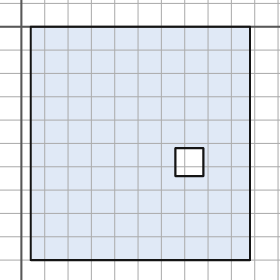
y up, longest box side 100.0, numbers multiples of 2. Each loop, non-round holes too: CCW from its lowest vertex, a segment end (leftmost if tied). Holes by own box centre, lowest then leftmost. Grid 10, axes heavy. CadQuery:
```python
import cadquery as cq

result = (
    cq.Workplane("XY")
    .moveTo(4.0, -100.0)
    .lineTo(98.0, -100.0)
    .lineTo(98.0, 0.0)
    .lineTo(4.0, 0.0)
    .close()
    .moveTo(66.0, -64.0)
    .lineTo(78.0, -64.0)
    .lineTo(78.0, -52.0)
    .lineTo(66.0, -52.0)
    .close()
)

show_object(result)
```